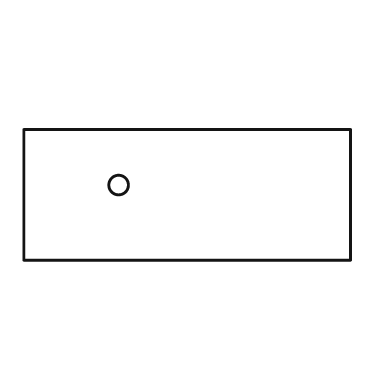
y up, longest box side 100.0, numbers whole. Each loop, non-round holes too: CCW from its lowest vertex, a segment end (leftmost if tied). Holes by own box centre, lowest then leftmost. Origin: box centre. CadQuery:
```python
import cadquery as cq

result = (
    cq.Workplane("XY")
    .moveTo(-50.0, -20.0)
    .lineTo(50.0, -20.0)
    .lineTo(50.0, 20.0)
    .lineTo(-50.0, 20.0)
    .close()
    .moveTo(-21.0, 3.0)
    .circle(3.0)
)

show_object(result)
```